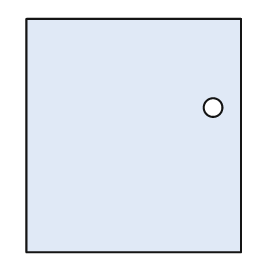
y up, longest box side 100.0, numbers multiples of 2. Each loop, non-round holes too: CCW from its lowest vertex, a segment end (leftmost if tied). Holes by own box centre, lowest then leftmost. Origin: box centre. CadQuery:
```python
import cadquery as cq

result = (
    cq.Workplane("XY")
    .moveTo(-46.0, -50.0)
    .lineTo(46.0, -50.0)
    .lineTo(46.0, 50.0)
    .lineTo(-46.0, 50.0)
    .close()
    .moveTo(34.0, 12.0)
    .circle(4.0)
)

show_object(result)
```